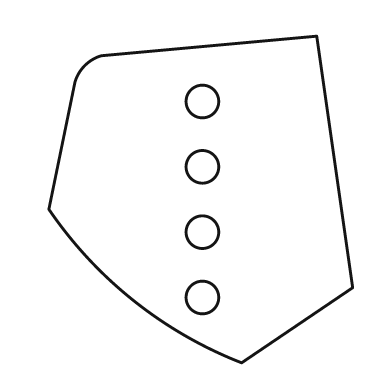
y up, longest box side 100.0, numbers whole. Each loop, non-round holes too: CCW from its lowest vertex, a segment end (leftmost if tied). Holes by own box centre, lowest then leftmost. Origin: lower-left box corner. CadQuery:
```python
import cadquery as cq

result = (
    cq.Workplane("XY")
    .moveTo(59.0, 0.0)
    .lineTo(93.0, 23.0)
    .lineTo(82.0, 100.0)
    .lineTo(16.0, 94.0)
    .threePointArc((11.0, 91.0), (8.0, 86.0))
    .lineTo(0.0, 47.0)
    .threePointArc((26.0, 19.0), (59.0, 0.0))
    .close()
    .moveTo(47.0, 20.0)
    .circle(5.0)
    .moveTo(47.0, 40.0)
    .circle(5.0)
    .moveTo(47.0, 60.0)
    .circle(5.0)
    .moveTo(47.0, 80.0)
    .circle(5.0)
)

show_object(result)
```